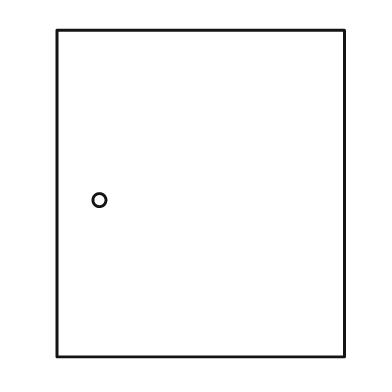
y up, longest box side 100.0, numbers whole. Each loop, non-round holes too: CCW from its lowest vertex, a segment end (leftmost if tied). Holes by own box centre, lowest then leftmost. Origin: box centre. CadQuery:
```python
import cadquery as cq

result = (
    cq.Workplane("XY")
    .moveTo(-44.0, -50.0)
    .lineTo(44.0, -50.0)
    .lineTo(44.0, 50.0)
    .lineTo(-44.0, 50.0)
    .close()
    .moveTo(-31.0, -2.0)
    .circle(2.0)
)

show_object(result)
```